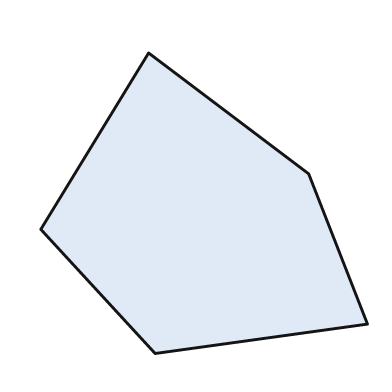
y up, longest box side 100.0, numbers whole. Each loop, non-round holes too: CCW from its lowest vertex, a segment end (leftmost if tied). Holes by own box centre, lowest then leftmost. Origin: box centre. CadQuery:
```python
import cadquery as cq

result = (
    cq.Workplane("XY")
    .moveTo(-15.0, -46.0)
    .lineTo(50.0, -37.0)
    .lineTo(32.0, 9.0)
    .lineTo(-17.0, 46.0)
    .lineTo(-50.0, -8.0)
    .close()
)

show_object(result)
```